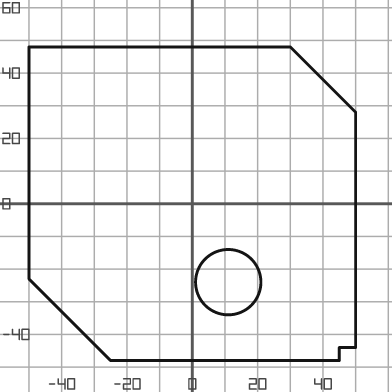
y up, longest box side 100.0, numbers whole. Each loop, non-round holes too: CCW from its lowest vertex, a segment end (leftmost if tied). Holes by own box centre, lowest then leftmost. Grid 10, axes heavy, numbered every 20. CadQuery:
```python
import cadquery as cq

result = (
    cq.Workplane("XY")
    .moveTo(-25.0, -48.0)
    .lineTo(45.0, -48.0)
    .lineTo(45.0, -44.0)
    .lineTo(50.0, -44.0)
    .lineTo(50.0, 28.0)
    .lineTo(30.0, 48.0)
    .lineTo(-50.0, 48.0)
    .lineTo(-50.0, -23.0)
    .close()
    .moveTo(11.0, -24.0)
    .circle(10.0)
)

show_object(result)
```